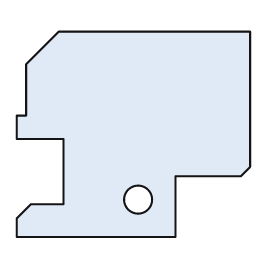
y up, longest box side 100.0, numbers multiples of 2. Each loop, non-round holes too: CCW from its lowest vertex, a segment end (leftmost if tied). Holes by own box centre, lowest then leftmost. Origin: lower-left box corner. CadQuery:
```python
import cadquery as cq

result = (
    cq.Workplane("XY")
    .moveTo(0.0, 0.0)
    .lineTo(68.0, 0.0)
    .lineTo(68.0, 26.0)
    .lineTo(96.0, 26.0)
    .lineTo(100.0, 30.0)
    .lineTo(100.0, 88.0)
    .lineTo(18.0, 88.0)
    .lineTo(4.0, 74.0)
    .lineTo(4.0, 52.0)
    .lineTo(0.0, 52.0)
    .lineTo(0.0, 42.0)
    .lineTo(20.0, 42.0)
    .lineTo(20.0, 14.0)
    .lineTo(6.0, 14.0)
    .lineTo(0.0, 8.0)
    .close()
    .moveTo(52.0, 16.0)
    .circle(6.0)
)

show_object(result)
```